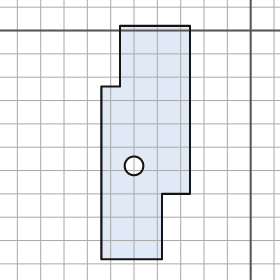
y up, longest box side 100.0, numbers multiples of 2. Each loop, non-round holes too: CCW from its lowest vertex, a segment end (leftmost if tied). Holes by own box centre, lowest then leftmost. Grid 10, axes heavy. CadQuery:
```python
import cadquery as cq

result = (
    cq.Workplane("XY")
    .moveTo(-64.0, -98.0)
    .lineTo(-38.0, -98.0)
    .lineTo(-38.0, -70.0)
    .lineTo(-26.0, -70.0)
    .lineTo(-26.0, 2.0)
    .lineTo(-56.0, 2.0)
    .lineTo(-56.0, -24.0)
    .lineTo(-64.0, -24.0)
    .close()
    .moveTo(-50.0, -58.0)
    .circle(4.0)
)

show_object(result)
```